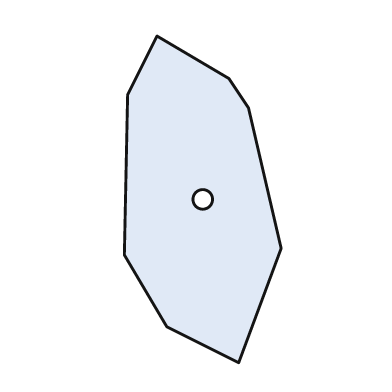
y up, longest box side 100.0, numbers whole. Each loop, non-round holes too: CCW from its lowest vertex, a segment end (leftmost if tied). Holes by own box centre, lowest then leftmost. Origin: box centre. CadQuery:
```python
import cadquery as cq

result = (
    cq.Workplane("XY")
    .moveTo(11.0, -50.0)
    .lineTo(24.0, -15.0)
    .lineTo(14.0, 28.0)
    .lineTo(8.0, 37.0)
    .lineTo(-14.0, 50.0)
    .lineTo(-23.0, 32.0)
    .lineTo(-24.0, -17.0)
    .lineTo(-11.0, -39.0)
    .close()
    .moveTo(0.0, 0.0)
    .circle(3.0)
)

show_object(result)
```